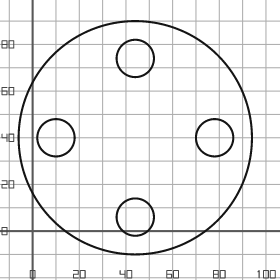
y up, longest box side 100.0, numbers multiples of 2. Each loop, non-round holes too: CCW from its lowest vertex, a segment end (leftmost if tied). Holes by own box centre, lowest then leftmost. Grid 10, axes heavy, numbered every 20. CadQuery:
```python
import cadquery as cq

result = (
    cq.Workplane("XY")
    .moveTo(44.0, 40.0)
    .circle(50.0)
    .moveTo(44.0, 6.0)
    .circle(8.0)
    .moveTo(10.0, 40.0)
    .circle(8.0)
    .moveTo(78.0, 40.0)
    .circle(8.0)
    .moveTo(44.0, 74.0)
    .circle(8.0)
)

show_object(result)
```